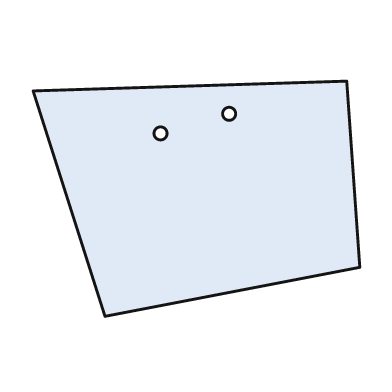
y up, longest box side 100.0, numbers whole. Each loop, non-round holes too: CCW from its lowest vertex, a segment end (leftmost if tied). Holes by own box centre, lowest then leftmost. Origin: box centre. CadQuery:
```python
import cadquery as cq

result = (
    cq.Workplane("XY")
    .moveTo(-28.0, -36.0)
    .lineTo(50.0, -21.0)
    .lineTo(46.0, 36.0)
    .lineTo(-50.0, 33.0)
    .close()
    .moveTo(-11.0, 20.0)
    .circle(2.0)
    .moveTo(10.0, 26.0)
    .circle(2.0)
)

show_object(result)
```